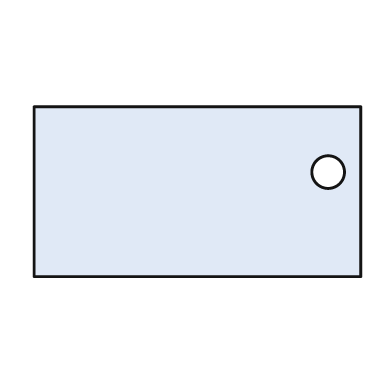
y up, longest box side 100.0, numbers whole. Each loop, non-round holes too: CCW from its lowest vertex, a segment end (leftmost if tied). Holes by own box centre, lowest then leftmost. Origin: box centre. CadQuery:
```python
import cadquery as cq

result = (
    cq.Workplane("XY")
    .moveTo(-50.0, -26.0)
    .lineTo(50.0, -26.0)
    .lineTo(50.0, 26.0)
    .lineTo(-50.0, 26.0)
    .close()
    .moveTo(40.0, 6.0)
    .circle(5.0)
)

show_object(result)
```